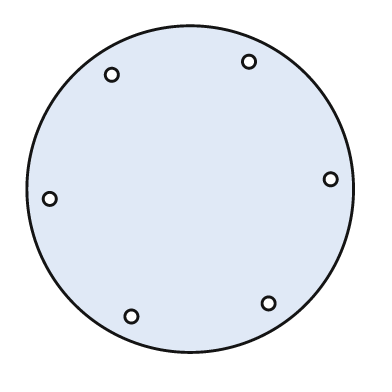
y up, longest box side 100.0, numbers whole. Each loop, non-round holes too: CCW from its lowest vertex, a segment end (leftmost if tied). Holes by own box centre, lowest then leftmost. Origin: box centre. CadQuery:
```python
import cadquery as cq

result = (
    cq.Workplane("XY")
    .moveTo(0.0, 0.0)
    .circle(50.0)
    .moveTo(-18.0, -39.0)
    .circle(2.0)
    .moveTo(24.0, -35.0)
    .circle(2.0)
    .moveTo(-43.0, -3.0)
    .circle(2.0)
    .moveTo(43.0, 3.0)
    .circle(2.0)
    .moveTo(-24.0, 35.0)
    .circle(2.0)
    .moveTo(18.0, 39.0)
    .circle(2.0)
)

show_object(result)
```